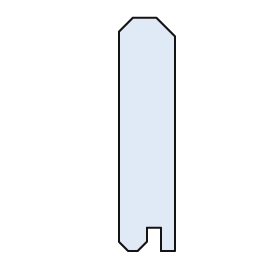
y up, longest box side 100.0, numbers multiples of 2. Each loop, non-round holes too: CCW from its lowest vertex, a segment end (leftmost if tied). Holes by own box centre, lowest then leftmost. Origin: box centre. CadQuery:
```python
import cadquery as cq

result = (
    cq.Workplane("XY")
    .moveTo(-8.0, -50.0)
    .lineTo(-4.0, -50.0)
    .lineTo(0.0, -46.0)
    .lineTo(0.0, -40.0)
    .lineTo(6.0, -40.0)
    .lineTo(6.0, -50.0)
    .lineTo(12.0, -50.0)
    .lineTo(12.0, 42.0)
    .lineTo(4.0, 50.0)
    .lineTo(-6.0, 50.0)
    .lineTo(-12.0, 44.0)
    .lineTo(-12.0, -46.0)
    .close()
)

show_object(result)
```